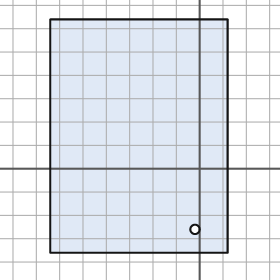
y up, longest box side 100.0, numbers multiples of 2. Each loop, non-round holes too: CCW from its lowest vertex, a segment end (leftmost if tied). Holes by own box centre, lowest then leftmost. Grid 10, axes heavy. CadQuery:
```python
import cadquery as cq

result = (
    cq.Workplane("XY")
    .moveTo(-64.0, -36.0)
    .lineTo(12.0, -36.0)
    .lineTo(12.0, 64.0)
    .lineTo(-64.0, 64.0)
    .close()
    .moveTo(-2.0, -26.0)
    .circle(2.0)
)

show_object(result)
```